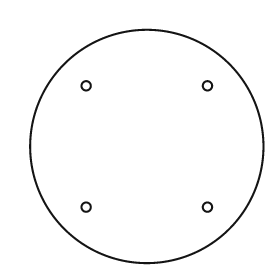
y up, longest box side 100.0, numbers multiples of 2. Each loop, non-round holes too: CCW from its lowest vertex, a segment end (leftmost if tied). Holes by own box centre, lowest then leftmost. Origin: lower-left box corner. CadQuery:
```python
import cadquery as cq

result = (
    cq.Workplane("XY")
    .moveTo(50.0, 50.0)
    .circle(50.0)
    .moveTo(24.0, 24.0)
    .circle(2.0)
    .moveTo(76.0, 24.0)
    .circle(2.0)
    .moveTo(24.0, 76.0)
    .circle(2.0)
    .moveTo(76.0, 76.0)
    .circle(2.0)
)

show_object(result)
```